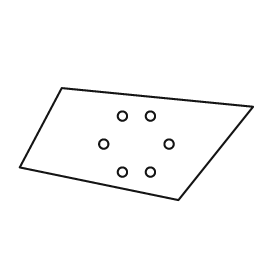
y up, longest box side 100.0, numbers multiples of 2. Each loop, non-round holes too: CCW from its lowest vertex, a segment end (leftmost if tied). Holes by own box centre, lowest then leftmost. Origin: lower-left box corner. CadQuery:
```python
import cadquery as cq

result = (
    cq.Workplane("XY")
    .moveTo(68.0, 0.0)
    .lineTo(100.0, 40.0)
    .lineTo(18.0, 48.0)
    .lineTo(0.0, 14.0)
    .close()
    .moveTo(44.0, 12.0)
    .circle(2.0)
    .moveTo(56.0, 12.0)
    .circle(2.0)
    .moveTo(36.0, 24.0)
    .circle(2.0)
    .moveTo(64.0, 24.0)
    .circle(2.0)
    .moveTo(44.0, 36.0)
    .circle(2.0)
    .moveTo(56.0, 36.0)
    .circle(2.0)
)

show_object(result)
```